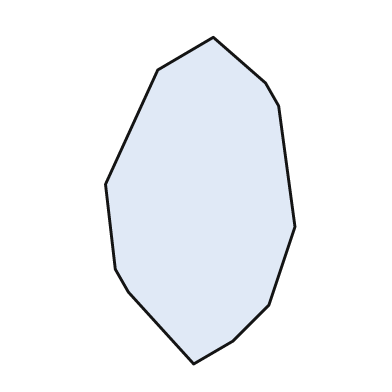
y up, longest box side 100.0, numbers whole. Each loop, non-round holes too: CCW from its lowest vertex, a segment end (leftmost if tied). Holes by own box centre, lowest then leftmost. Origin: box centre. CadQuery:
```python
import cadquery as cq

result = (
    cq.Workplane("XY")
    .moveTo(-2.0, -50.0)
    .lineTo(10.0, -43.0)
    .lineTo(21.0, -32.0)
    .lineTo(29.0, -8.0)
    .lineTo(24.0, 29.0)
    .lineTo(20.0, 36.0)
    .lineTo(4.0, 50.0)
    .lineTo(-13.0, 40.0)
    .lineTo(-29.0, 5.0)
    .lineTo(-26.0, -21.0)
    .lineTo(-22.0, -28.0)
    .close()
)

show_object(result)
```